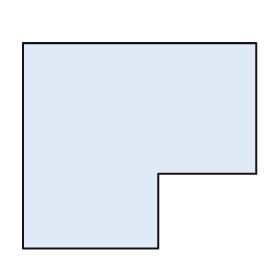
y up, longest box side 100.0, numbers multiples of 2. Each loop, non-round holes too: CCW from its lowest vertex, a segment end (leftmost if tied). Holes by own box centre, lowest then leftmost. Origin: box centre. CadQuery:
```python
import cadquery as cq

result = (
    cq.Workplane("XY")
    .moveTo(-50.0, -44.0)
    .lineTo(8.0, -44.0)
    .lineTo(8.0, -12.0)
    .lineTo(50.0, -12.0)
    .lineTo(50.0, 44.0)
    .lineTo(-50.0, 44.0)
    .close()
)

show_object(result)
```